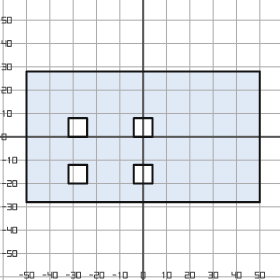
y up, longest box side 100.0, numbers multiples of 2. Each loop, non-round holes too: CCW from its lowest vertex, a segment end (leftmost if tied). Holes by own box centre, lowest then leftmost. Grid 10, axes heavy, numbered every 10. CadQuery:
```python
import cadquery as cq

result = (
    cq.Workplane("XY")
    .moveTo(-50.0, -28.0)
    .lineTo(50.0, -28.0)
    .lineTo(50.0, 28.0)
    .lineTo(-50.0, 28.0)
    .close()
    .moveTo(-32.0, -20.0)
    .lineTo(-24.0, -20.0)
    .lineTo(-24.0, -12.0)
    .lineTo(-32.0, -12.0)
    .close()
    .moveTo(-4.0, -20.0)
    .lineTo(4.0, -20.0)
    .lineTo(4.0, -12.0)
    .lineTo(-4.0, -12.0)
    .close()
    .moveTo(-32.0, 0.0)
    .lineTo(-24.0, 0.0)
    .lineTo(-24.0, 8.0)
    .lineTo(-32.0, 8.0)
    .close()
    .moveTo(-4.0, 0.0)
    .lineTo(4.0, 0.0)
    .lineTo(4.0, 8.0)
    .lineTo(-4.0, 8.0)
    .close()
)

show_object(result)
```